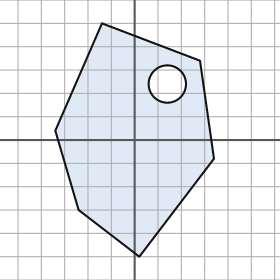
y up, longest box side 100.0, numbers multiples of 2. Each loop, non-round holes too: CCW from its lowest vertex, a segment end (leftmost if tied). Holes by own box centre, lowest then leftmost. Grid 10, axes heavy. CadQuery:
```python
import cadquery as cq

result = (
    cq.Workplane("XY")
    .moveTo(2.0, -50.0)
    .lineTo(34.0, -8.0)
    .lineTo(28.0, 34.0)
    .lineTo(-14.0, 50.0)
    .lineTo(-34.0, 4.0)
    .lineTo(-24.0, -30.0)
    .close()
    .moveTo(14.0, 24.0)
    .circle(8.0)
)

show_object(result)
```